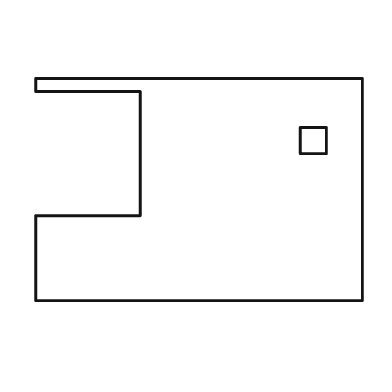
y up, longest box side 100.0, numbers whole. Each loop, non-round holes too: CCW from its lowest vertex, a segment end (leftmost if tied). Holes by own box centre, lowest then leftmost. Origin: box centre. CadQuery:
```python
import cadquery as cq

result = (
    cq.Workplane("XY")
    .moveTo(-50.0, -34.0)
    .lineTo(50.0, -34.0)
    .lineTo(50.0, 34.0)
    .lineTo(-50.0, 34.0)
    .lineTo(-50.0, 30.0)
    .lineTo(-18.0, 30.0)
    .lineTo(-18.0, -8.0)
    .lineTo(-50.0, -8.0)
    .close()
    .moveTo(31.0, 11.0)
    .lineTo(39.0, 11.0)
    .lineTo(39.0, 19.0)
    .lineTo(31.0, 19.0)
    .close()
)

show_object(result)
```